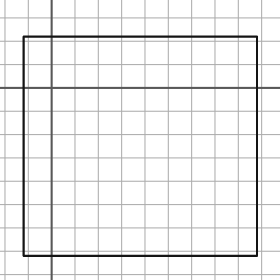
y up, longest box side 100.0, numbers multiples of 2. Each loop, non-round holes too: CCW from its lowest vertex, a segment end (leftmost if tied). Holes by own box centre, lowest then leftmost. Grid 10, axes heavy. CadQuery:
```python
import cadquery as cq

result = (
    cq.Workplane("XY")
    .moveTo(-12.0, -72.0)
    .lineTo(88.0, -72.0)
    .lineTo(88.0, 22.0)
    .lineTo(-12.0, 22.0)
    .close()
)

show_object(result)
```